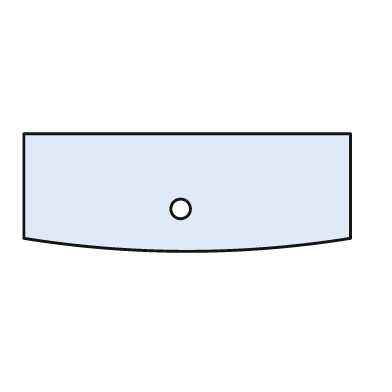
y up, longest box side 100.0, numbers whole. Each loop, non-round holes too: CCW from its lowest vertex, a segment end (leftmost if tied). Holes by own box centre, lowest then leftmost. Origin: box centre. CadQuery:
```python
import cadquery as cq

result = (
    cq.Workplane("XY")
    .moveTo(-50.0, -14.0)
    .threePointArc((0.0, -18.0), (50.0, -14.0))
    .lineTo(50.0, 18.0)
    .lineTo(-50.0, 18.0)
    .close()
    .moveTo(-2.0, -5.0)
    .circle(3.0)
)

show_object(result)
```